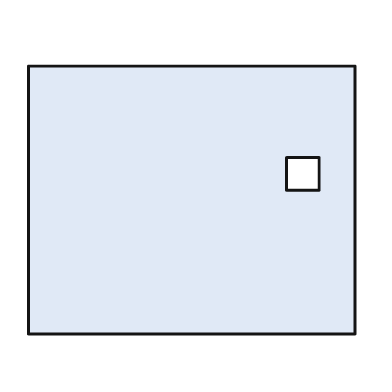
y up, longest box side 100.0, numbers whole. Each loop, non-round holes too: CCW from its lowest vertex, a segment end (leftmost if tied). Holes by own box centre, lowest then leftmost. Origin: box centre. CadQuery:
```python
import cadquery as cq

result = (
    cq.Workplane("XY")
    .moveTo(-50.0, -41.0)
    .lineTo(50.0, -41.0)
    .lineTo(50.0, 41.0)
    .lineTo(-50.0, 41.0)
    .close()
    .moveTo(29.0, 3.0)
    .lineTo(39.0, 3.0)
    .lineTo(39.0, 13.0)
    .lineTo(29.0, 13.0)
    .close()
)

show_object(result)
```